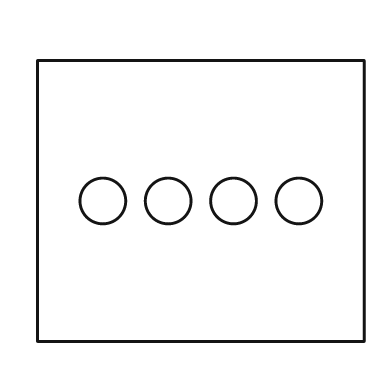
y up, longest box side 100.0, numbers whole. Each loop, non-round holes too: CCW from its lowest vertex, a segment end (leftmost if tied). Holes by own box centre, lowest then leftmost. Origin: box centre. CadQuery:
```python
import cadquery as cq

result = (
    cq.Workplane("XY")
    .moveTo(-50.0, -43.0)
    .lineTo(50.0, -43.0)
    .lineTo(50.0, 43.0)
    .lineTo(-50.0, 43.0)
    .close()
    .moveTo(-30.0, 0.0)
    .circle(7.0)
    .moveTo(-10.0, 0.0)
    .circle(7.0)
    .moveTo(10.0, 0.0)
    .circle(7.0)
    .moveTo(30.0, 0.0)
    .circle(7.0)
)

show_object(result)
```